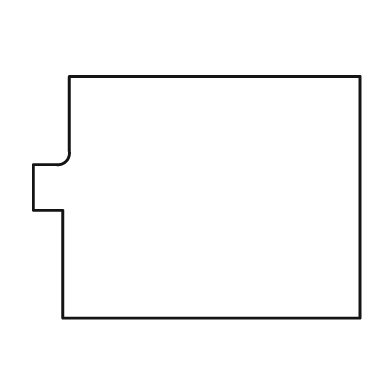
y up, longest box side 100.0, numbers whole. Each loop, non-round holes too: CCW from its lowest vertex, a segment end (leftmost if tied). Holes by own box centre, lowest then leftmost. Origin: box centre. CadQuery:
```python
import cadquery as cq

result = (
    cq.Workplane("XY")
    .moveTo(-41.0, -37.0)
    .lineTo(50.0, -37.0)
    .lineTo(50.0, 37.0)
    .lineTo(-39.0, 37.0)
    .lineTo(-39.0, 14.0)
    .threePointArc((-40.0, 11.0), (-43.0, 10.0))
    .lineTo(-50.0, 10.0)
    .lineTo(-50.0, -4.0)
    .lineTo(-41.0, -4.0)
    .close()
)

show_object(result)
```